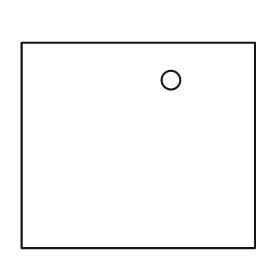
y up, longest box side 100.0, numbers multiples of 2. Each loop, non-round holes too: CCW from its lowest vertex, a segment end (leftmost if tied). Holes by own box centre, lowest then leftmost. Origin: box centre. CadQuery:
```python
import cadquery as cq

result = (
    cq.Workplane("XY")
    .moveTo(-50.0, -44.0)
    .lineTo(50.0, -44.0)
    .lineTo(50.0, 44.0)
    .lineTo(-50.0, 44.0)
    .close()
    .moveTo(14.0, 28.0)
    .circle(4.0)
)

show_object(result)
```